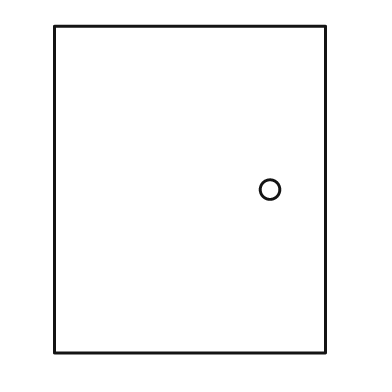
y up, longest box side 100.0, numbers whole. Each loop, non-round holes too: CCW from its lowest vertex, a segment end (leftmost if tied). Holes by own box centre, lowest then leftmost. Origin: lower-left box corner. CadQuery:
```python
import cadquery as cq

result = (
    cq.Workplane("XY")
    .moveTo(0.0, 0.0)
    .lineTo(83.0, 0.0)
    .lineTo(83.0, 100.0)
    .lineTo(0.0, 100.0)
    .close()
    .moveTo(66.0, 50.0)
    .circle(3.0)
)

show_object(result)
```